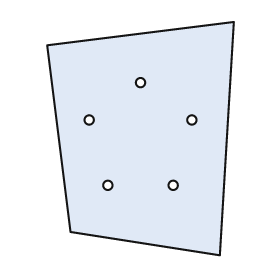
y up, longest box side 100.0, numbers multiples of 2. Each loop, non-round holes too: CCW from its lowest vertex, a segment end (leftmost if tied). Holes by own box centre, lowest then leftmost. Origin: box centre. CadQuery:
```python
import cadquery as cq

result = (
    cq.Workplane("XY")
    .moveTo(34.0, -50.0)
    .lineTo(40.0, 50.0)
    .lineTo(-40.0, 40.0)
    .lineTo(-30.0, -40.0)
    .close()
    .moveTo(-14.0, -20.0)
    .circle(2.0)
    .moveTo(14.0, -20.0)
    .circle(2.0)
    .moveTo(-22.0, 8.0)
    .circle(2.0)
    .moveTo(22.0, 8.0)
    .circle(2.0)
    .moveTo(0.0, 24.0)
    .circle(2.0)
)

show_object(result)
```